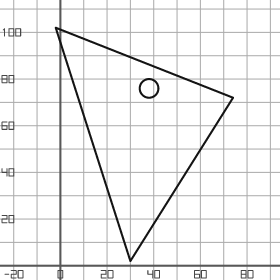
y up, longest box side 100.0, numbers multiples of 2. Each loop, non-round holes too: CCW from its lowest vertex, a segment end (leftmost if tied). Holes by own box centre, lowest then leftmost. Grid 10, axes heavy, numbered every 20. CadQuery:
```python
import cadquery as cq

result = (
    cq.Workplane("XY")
    .moveTo(30.0, 2.0)
    .lineTo(74.0, 72.0)
    .lineTo(-2.0, 102.0)
    .close()
    .moveTo(38.0, 76.0)
    .circle(4.0)
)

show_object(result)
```